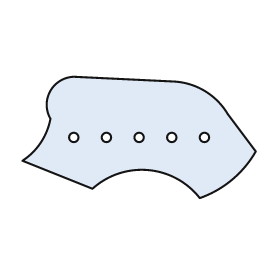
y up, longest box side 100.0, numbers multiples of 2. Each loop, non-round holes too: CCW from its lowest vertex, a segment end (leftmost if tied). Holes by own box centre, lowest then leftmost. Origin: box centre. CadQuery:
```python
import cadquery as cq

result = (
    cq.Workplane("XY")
    .moveTo(26.0, -26.0)
    .threePointArc((40.0, -18.0), (50.0, -6.0))
    .lineTo(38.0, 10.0)
    .threePointArc((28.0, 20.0), (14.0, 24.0))
    .lineTo(-28.0, 26.0)
    .threePointArc((-38.0, 20.0), (-38.0, 8.0))
    .threePointArc((-42.0, -2.0), (-50.0, -10.0))
    .lineTo(-20.0, -22.0)
    .threePointArc((4.0, -14.0), (26.0, -26.0))
    .close()
    .moveTo(-28.0, 0.0)
    .circle(2.0)
    .moveTo(-14.0, 0.0)
    .circle(2.0)
    .moveTo(0.0, 0.0)
    .circle(2.0)
    .moveTo(14.0, 0.0)
    .circle(2.0)
    .moveTo(28.0, 0.0)
    .circle(2.0)
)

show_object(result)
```